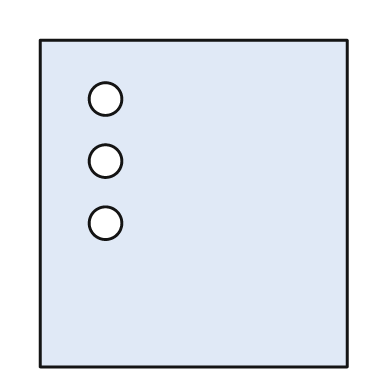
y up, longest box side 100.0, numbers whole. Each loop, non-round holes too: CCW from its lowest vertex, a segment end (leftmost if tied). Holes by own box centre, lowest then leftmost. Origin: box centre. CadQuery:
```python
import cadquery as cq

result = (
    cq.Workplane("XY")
    .moveTo(-47.0, -50.0)
    .lineTo(47.0, -50.0)
    .lineTo(47.0, 50.0)
    .lineTo(-47.0, 50.0)
    .close()
    .moveTo(-27.0, -6.0)
    .circle(5.0)
    .moveTo(-27.0, 13.0)
    .circle(5.0)
    .moveTo(-27.0, 32.0)
    .circle(5.0)
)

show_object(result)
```